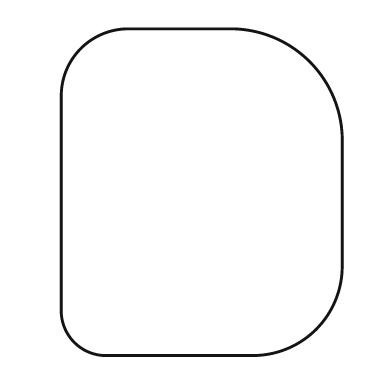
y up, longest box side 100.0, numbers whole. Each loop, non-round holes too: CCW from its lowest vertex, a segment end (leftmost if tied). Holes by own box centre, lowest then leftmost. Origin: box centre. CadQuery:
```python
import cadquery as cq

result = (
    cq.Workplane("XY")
    .moveTo(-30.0, -50.0)
    .lineTo(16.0, -50.0)
    .threePointArc((35.0, -42.0), (43.0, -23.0))
    .lineTo(43.0, 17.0)
    .threePointArc((33.0, 40.0), (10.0, 50.0))
    .lineTo(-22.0, 50.0)
    .threePointArc((-37.0, 44.0), (-43.0, 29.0))
    .lineTo(-43.0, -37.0)
    .threePointArc((-39.0, -46.0), (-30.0, -50.0))
    .close()
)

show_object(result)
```